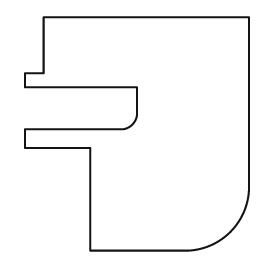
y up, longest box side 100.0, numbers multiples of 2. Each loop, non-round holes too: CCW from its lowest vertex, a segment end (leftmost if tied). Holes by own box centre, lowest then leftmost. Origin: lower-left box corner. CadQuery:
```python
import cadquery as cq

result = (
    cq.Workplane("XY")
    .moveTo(28.0, 0.0)
    .lineTo(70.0, 0.0)
    .threePointArc((88.0, 8.0), (96.0, 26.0))
    .lineTo(96.0, 100.0)
    .lineTo(8.0, 100.0)
    .lineTo(8.0, 76.0)
    .lineTo(0.0, 76.0)
    .lineTo(0.0, 70.0)
    .lineTo(48.0, 70.0)
    .lineTo(48.0, 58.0)
    .threePointArc((46.0, 54.0), (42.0, 52.0))
    .lineTo(0.0, 52.0)
    .lineTo(0.0, 44.0)
    .lineTo(28.0, 44.0)
    .close()
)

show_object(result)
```